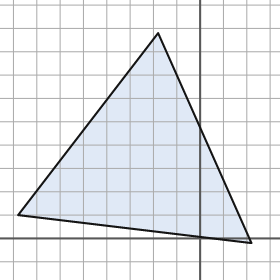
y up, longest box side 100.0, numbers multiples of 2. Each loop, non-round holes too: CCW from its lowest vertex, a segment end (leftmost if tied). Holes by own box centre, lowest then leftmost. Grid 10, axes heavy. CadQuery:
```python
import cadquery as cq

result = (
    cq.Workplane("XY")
    .moveTo(22.0, -2.0)
    .lineTo(-18.0, 88.0)
    .lineTo(-78.0, 10.0)
    .close()
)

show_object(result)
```